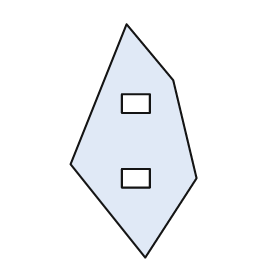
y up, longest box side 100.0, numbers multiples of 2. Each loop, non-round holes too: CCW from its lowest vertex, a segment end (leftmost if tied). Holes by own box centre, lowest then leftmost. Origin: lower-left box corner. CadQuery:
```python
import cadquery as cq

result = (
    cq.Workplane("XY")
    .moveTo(32.0, 0.0)
    .lineTo(54.0, 34.0)
    .lineTo(44.0, 76.0)
    .lineTo(24.0, 100.0)
    .lineTo(0.0, 40.0)
    .close()
    .moveTo(22.0, 30.0)
    .lineTo(34.0, 30.0)
    .lineTo(34.0, 38.0)
    .lineTo(22.0, 38.0)
    .close()
    .moveTo(22.0, 62.0)
    .lineTo(34.0, 62.0)
    .lineTo(34.0, 70.0)
    .lineTo(22.0, 70.0)
    .close()
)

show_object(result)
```